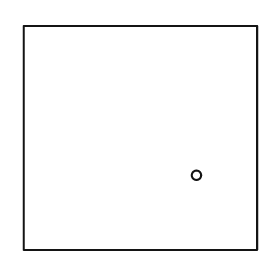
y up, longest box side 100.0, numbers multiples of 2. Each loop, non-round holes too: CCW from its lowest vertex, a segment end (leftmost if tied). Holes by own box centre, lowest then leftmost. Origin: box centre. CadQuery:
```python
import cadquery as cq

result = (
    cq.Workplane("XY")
    .moveTo(-50.0, -48.0)
    .lineTo(50.0, -48.0)
    .lineTo(50.0, 48.0)
    .lineTo(-50.0, 48.0)
    .close()
    .moveTo(24.0, -16.0)
    .circle(2.0)
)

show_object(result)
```